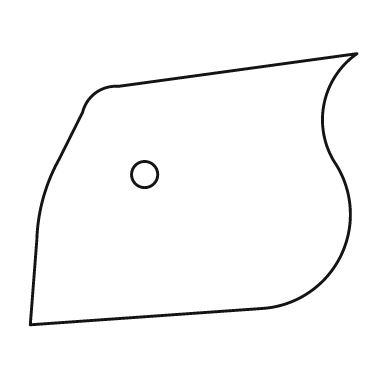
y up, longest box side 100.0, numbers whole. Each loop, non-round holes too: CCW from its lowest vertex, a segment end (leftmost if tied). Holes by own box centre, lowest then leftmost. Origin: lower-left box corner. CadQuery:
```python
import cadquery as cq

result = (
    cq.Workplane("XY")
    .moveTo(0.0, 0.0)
    .lineTo(71.0, 5.0)
    .threePointArc((95.0, 21.0), (93.0, 50.0))
    .threePointArc((90.0, 68.0), (100.0, 83.0))
    .lineTo(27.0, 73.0)
    .threePointArc((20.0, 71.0), (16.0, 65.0))
    .lineTo(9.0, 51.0)
    .threePointArc((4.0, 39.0), (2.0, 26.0))
    .close()
    .moveTo(35.0, 46.0)
    .circle(4.0)
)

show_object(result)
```